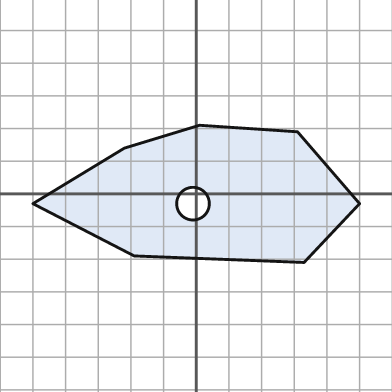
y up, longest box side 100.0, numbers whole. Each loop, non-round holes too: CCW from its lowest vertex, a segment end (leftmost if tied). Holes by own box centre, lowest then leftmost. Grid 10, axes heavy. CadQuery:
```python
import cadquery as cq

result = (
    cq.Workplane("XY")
    .moveTo(33.0, -21.0)
    .lineTo(50.0, -3.0)
    .lineTo(31.0, 19.0)
    .lineTo(1.0, 21.0)
    .lineTo(-22.0, 14.0)
    .lineTo(-50.0, -3.0)
    .lineTo(-19.0, -19.0)
    .close()
    .moveTo(-1.0, -3.0)
    .circle(5.0)
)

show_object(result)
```